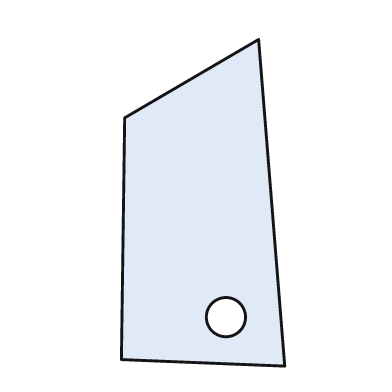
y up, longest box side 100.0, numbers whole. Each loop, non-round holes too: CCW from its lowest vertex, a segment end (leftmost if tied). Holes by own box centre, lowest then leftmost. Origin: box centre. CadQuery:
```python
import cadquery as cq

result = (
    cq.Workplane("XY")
    .moveTo(25.0, -50.0)
    .lineTo(17.0, 50.0)
    .lineTo(-24.0, 26.0)
    .lineTo(-25.0, -48.0)
    .close()
    .moveTo(7.0, -35.0)
    .circle(6.0)
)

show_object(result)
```